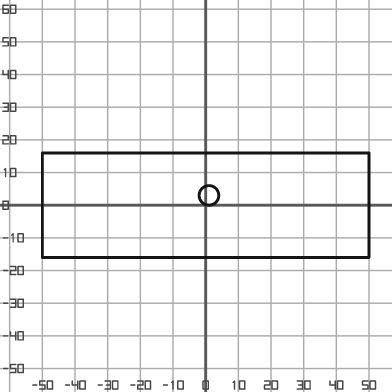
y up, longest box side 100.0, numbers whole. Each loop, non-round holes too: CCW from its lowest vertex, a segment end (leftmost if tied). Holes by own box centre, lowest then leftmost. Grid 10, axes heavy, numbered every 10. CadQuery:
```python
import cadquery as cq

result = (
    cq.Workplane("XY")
    .moveTo(-50.0, -16.0)
    .lineTo(50.0, -16.0)
    .lineTo(50.0, 16.0)
    .lineTo(-50.0, 16.0)
    .close()
    .moveTo(1.0, 3.0)
    .circle(3.0)
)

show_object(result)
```